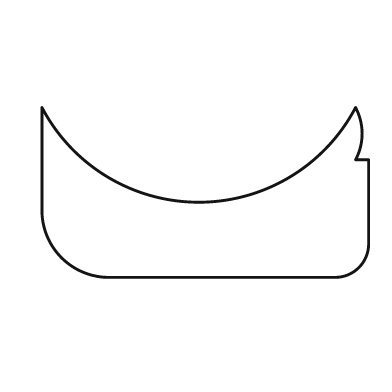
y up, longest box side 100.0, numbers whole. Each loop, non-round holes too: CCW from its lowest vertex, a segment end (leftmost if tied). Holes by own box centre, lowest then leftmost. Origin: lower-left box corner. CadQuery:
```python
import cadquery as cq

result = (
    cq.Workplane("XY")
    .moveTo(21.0, 0.0)
    .lineTo(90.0, 0.0)
    .threePointArc((97.0, 3.0), (100.0, 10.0))
    .lineTo(100.0, 36.0)
    .lineTo(96.0, 36.0)
    .threePointArc((98.0, 44.0), (96.0, 52.0))
    .threePointArc((48.0, 23.0), (0.0, 52.0))
    .lineTo(0.0, 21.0)
    .threePointArc((6.0, 6.0), (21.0, 0.0))
    .close()
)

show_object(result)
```